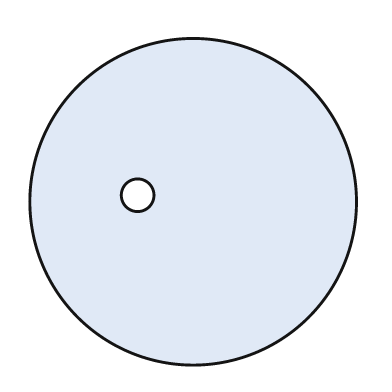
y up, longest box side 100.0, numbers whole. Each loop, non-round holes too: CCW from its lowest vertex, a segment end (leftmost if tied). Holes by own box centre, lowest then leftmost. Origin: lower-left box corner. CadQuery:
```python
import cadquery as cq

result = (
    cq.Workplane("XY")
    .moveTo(50.0, 50.0)
    .circle(50.0)
    .moveTo(33.0, 52.0)
    .circle(5.0)
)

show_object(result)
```